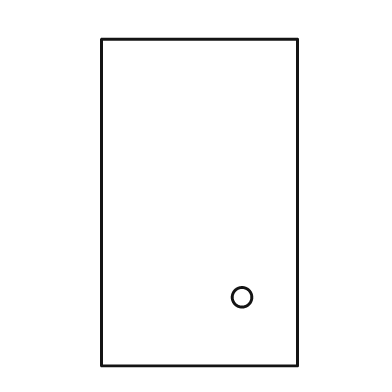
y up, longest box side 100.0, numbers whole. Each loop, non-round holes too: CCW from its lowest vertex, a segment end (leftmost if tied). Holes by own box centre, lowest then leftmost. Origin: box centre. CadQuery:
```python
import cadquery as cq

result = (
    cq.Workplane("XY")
    .moveTo(-30.0, -50.0)
    .lineTo(30.0, -50.0)
    .lineTo(30.0, 50.0)
    .lineTo(-30.0, 50.0)
    .close()
    .moveTo(13.0, -29.0)
    .circle(3.0)
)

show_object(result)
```